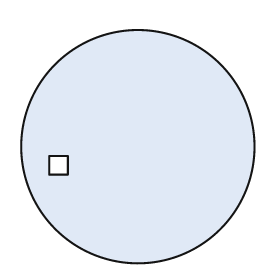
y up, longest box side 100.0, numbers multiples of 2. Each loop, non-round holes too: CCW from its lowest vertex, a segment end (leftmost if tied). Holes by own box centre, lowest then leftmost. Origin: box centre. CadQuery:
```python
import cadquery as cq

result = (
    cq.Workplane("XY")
    .moveTo(0.0, 0.0)
    .circle(50.0)
    .moveTo(-38.0, -12.0)
    .lineTo(-30.0, -12.0)
    .lineTo(-30.0, -4.0)
    .lineTo(-38.0, -4.0)
    .close()
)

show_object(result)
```